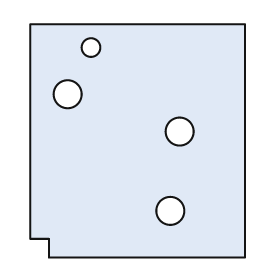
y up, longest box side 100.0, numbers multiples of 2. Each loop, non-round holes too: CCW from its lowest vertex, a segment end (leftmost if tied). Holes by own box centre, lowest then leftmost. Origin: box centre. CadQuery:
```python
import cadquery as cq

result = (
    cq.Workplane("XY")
    .moveTo(-38.0, -50.0)
    .lineTo(46.0, -50.0)
    .lineTo(46.0, 50.0)
    .lineTo(-46.0, 50.0)
    .lineTo(-46.0, -42.0)
    .lineTo(-38.0, -42.0)
    .close()
    .moveTo(14.0, -30.0)
    .circle(6.0)
    .moveTo(18.0, 4.0)
    .circle(6.0)
    .moveTo(-30.0, 20.0)
    .circle(6.0)
    .moveTo(-20.0, 40.0)
    .circle(4.0)
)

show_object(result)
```